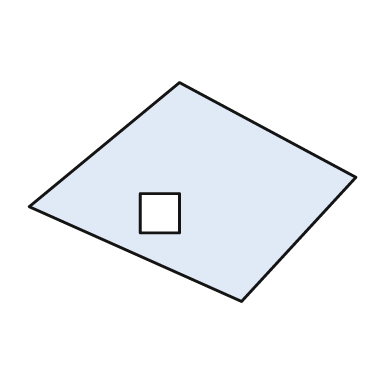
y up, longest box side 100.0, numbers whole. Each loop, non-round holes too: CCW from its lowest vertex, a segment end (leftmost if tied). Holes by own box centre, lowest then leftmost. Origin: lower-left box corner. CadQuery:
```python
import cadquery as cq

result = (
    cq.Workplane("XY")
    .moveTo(65.0, 0.0)
    .lineTo(100.0, 38.0)
    .lineTo(46.0, 67.0)
    .lineTo(0.0, 29.0)
    .close()
    .moveTo(34.0, 21.0)
    .lineTo(46.0, 21.0)
    .lineTo(46.0, 33.0)
    .lineTo(34.0, 33.0)
    .close()
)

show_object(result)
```